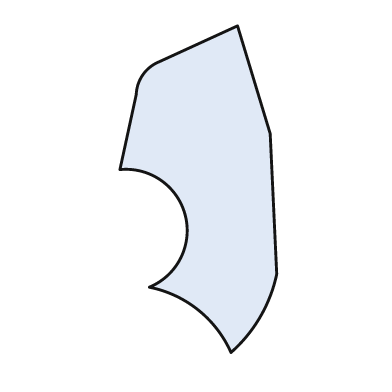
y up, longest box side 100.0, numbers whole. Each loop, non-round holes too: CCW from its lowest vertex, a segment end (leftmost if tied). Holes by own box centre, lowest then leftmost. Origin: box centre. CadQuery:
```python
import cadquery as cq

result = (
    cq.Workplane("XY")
    .moveTo(10.0, -50.0)
    .threePointArc((19.0, -39.0), (24.0, -26.0))
    .lineTo(22.0, 17.0)
    .lineTo(12.0, 50.0)
    .lineTo(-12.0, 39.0)
    .threePointArc((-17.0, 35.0), (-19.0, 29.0))
    .lineTo(-24.0, 6.0)
    .threePointArc((-4.0, -8.0), (-15.0, -30.0))
    .threePointArc((0.0, -37.0), (10.0, -50.0))
    .close()
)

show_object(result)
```